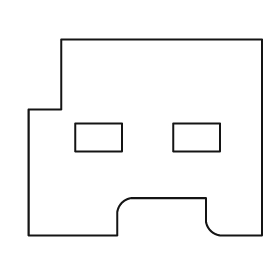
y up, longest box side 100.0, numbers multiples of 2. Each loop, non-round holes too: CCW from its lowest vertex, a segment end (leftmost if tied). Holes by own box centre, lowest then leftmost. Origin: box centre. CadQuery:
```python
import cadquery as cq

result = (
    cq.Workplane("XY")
    .moveTo(-50.0, -42.0)
    .lineTo(-12.0, -42.0)
    .lineTo(-12.0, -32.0)
    .threePointArc((-10.0, -28.0), (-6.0, -26.0))
    .lineTo(26.0, -26.0)
    .lineTo(26.0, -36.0)
    .threePointArc((28.0, -40.0), (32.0, -42.0))
    .lineTo(50.0, -42.0)
    .lineTo(50.0, 42.0)
    .lineTo(-36.0, 42.0)
    .lineTo(-36.0, 12.0)
    .lineTo(-50.0, 12.0)
    .close()
    .moveTo(-30.0, -6.0)
    .lineTo(-10.0, -6.0)
    .lineTo(-10.0, 6.0)
    .lineTo(-30.0, 6.0)
    .close()
    .moveTo(12.0, -6.0)
    .lineTo(32.0, -6.0)
    .lineTo(32.0, 6.0)
    .lineTo(12.0, 6.0)
    .close()
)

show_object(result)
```